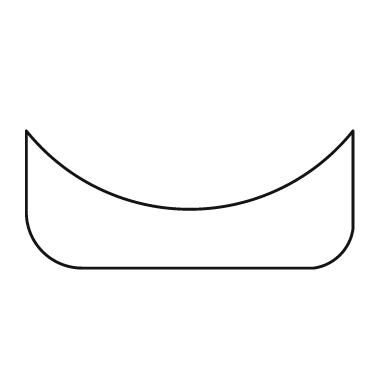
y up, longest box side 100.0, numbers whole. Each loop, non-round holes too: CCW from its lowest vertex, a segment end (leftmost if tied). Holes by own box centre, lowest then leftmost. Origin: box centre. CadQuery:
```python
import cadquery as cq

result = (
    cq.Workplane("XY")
    .moveTo(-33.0, -21.0)
    .lineTo(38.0, -21.0)
    .threePointArc((46.0, -17.0), (50.0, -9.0))
    .lineTo(50.0, 21.0)
    .threePointArc((0.0, -3.0), (-50.0, 21.0))
    .lineTo(-50.0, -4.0)
    .threePointArc((-45.0, -16.0), (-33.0, -21.0))
    .close()
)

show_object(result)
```